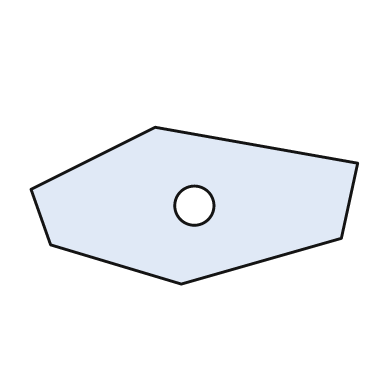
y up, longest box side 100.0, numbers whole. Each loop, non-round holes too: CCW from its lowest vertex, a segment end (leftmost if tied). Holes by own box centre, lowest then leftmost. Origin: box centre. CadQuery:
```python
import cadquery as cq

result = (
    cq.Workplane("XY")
    .moveTo(-4.0, -24.0)
    .lineTo(45.0, -10.0)
    .lineTo(50.0, 13.0)
    .lineTo(-12.0, 24.0)
    .lineTo(-50.0, 5.0)
    .lineTo(-44.0, -12.0)
    .close()
    .moveTo(0.0, 0.0)
    .circle(6.0)
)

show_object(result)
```